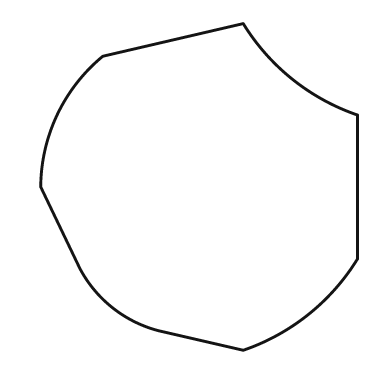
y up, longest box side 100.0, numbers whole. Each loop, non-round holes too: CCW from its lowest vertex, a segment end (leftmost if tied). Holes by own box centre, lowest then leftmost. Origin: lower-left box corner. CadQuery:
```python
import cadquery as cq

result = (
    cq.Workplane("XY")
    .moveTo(62.0, 0.0)
    .threePointArc((82.0, 11.0), (97.0, 28.0))
    .lineTo(97.0, 72.0)
    .threePointArc((77.0, 83.0), (62.0, 100.0))
    .lineTo(19.0, 90.0)
    .threePointArc((5.0, 72.0), (0.0, 50.0))
    .lineTo(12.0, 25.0)
    .threePointArc((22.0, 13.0), (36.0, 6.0))
    .close()
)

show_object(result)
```